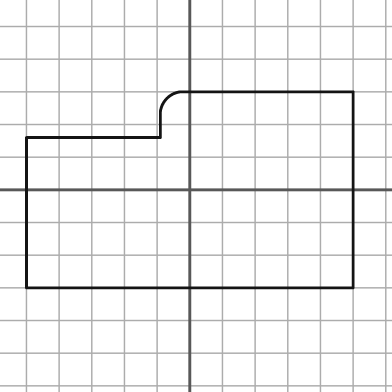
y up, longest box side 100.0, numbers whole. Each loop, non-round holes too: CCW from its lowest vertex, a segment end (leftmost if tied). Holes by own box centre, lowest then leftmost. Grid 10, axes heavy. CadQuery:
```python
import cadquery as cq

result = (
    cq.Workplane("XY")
    .moveTo(-50.0, -30.0)
    .lineTo(50.0, -30.0)
    .lineTo(50.0, 30.0)
    .lineTo(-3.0, 30.0)
    .threePointArc((-7.0, 28.0), (-9.0, 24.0))
    .lineTo(-9.0, 16.0)
    .lineTo(-50.0, 16.0)
    .close()
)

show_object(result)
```